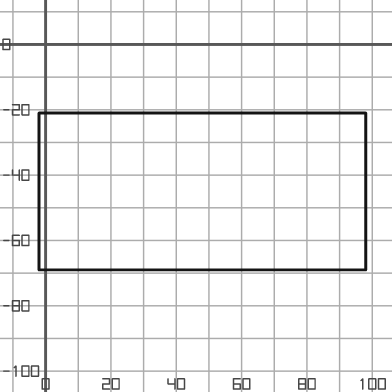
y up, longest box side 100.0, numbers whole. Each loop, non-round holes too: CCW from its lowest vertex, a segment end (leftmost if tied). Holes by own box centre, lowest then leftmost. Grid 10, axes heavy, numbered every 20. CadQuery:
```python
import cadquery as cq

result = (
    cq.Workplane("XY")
    .moveTo(-2.0, -69.0)
    .lineTo(98.0, -69.0)
    .lineTo(98.0, -21.0)
    .lineTo(-2.0, -21.0)
    .close()
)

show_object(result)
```